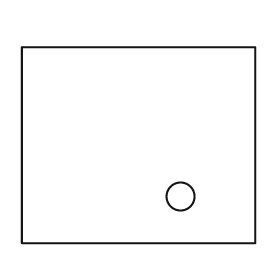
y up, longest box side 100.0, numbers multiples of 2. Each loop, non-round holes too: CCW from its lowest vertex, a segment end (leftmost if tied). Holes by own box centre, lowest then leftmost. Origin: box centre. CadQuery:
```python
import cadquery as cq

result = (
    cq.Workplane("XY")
    .moveTo(-50.0, -42.0)
    .lineTo(50.0, -42.0)
    .lineTo(50.0, 42.0)
    .lineTo(-50.0, 42.0)
    .close()
    .moveTo(18.0, -22.0)
    .circle(6.0)
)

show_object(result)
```